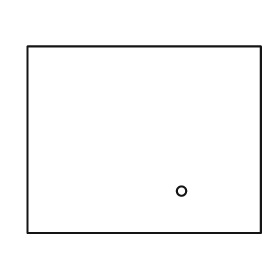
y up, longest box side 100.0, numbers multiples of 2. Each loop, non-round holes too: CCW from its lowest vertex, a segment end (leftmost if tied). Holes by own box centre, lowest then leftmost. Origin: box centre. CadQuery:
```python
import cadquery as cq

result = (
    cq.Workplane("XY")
    .moveTo(-50.0, -40.0)
    .lineTo(50.0, -40.0)
    .lineTo(50.0, 40.0)
    .lineTo(-50.0, 40.0)
    .close()
    .moveTo(16.0, -22.0)
    .circle(2.0)
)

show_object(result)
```